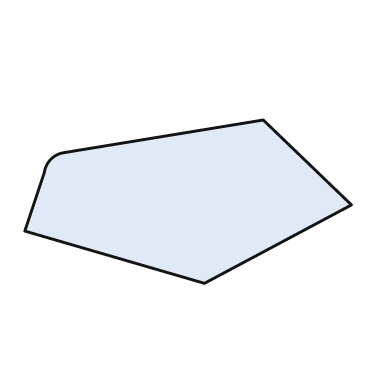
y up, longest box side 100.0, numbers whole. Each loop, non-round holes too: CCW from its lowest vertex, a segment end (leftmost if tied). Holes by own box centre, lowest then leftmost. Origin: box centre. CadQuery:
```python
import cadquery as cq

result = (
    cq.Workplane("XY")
    .moveTo(5.0, -25.0)
    .lineTo(50.0, -1.0)
    .lineTo(23.0, 25.0)
    .lineTo(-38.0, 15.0)
    .threePointArc((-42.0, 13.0), (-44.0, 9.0))
    .lineTo(-50.0, -9.0)
    .close()
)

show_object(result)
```